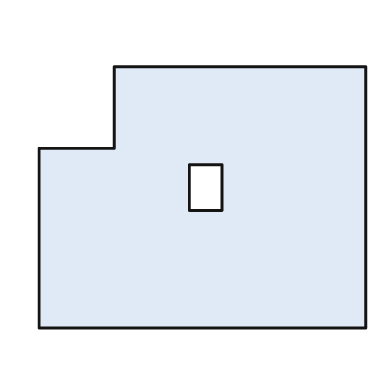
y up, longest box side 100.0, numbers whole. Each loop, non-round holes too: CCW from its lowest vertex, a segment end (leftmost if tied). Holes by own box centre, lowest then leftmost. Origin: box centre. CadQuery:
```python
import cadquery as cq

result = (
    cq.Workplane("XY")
    .moveTo(-50.0, -40.0)
    .lineTo(50.0, -40.0)
    .lineTo(50.0, 40.0)
    .lineTo(-27.0, 40.0)
    .lineTo(-27.0, 15.0)
    .lineTo(-50.0, 15.0)
    .close()
    .moveTo(-4.0, -4.0)
    .lineTo(6.0, -4.0)
    .lineTo(6.0, 10.0)
    .lineTo(-4.0, 10.0)
    .close()
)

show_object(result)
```